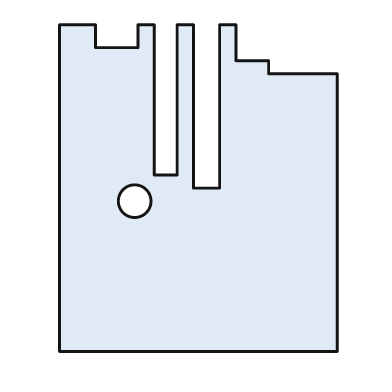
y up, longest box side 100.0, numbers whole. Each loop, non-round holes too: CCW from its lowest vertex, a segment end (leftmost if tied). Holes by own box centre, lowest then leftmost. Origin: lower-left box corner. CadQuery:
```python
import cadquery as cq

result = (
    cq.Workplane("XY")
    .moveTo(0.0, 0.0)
    .lineTo(85.0, 0.0)
    .lineTo(85.0, 85.0)
    .lineTo(64.0, 85.0)
    .lineTo(64.0, 89.0)
    .lineTo(54.0, 89.0)
    .lineTo(54.0, 100.0)
    .lineTo(49.0, 100.0)
    .lineTo(49.0, 50.0)
    .lineTo(41.0, 50.0)
    .lineTo(41.0, 100.0)
    .lineTo(36.0, 100.0)
    .lineTo(36.0, 54.0)
    .lineTo(29.0, 54.0)
    .lineTo(29.0, 100.0)
    .lineTo(24.0, 100.0)
    .lineTo(24.0, 93.0)
    .lineTo(11.0, 93.0)
    .lineTo(11.0, 100.0)
    .lineTo(0.0, 100.0)
    .close()
    .moveTo(23.0, 46.0)
    .circle(5.0)
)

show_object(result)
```